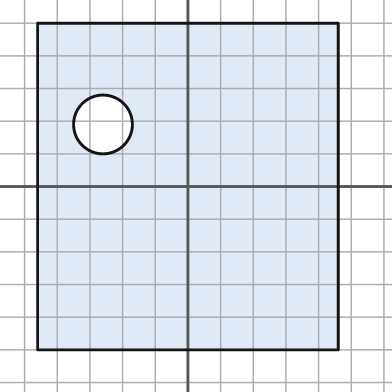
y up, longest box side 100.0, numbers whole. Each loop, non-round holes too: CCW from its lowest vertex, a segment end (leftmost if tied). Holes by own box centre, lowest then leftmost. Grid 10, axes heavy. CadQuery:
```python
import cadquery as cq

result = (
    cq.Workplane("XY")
    .moveTo(-46.0, -50.0)
    .lineTo(46.0, -50.0)
    .lineTo(46.0, 50.0)
    .lineTo(-46.0, 50.0)
    .close()
    .moveTo(-26.0, 19.0)
    .circle(9.0)
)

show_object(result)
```